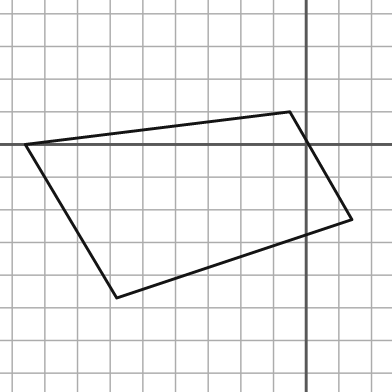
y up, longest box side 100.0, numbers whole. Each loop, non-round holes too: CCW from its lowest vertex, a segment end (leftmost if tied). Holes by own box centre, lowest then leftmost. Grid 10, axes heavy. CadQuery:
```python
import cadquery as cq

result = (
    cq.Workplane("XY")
    .moveTo(-58.0, -47.0)
    .lineTo(14.0, -23.0)
    .lineTo(-5.0, 10.0)
    .lineTo(-86.0, 0.0)
    .close()
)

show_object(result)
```